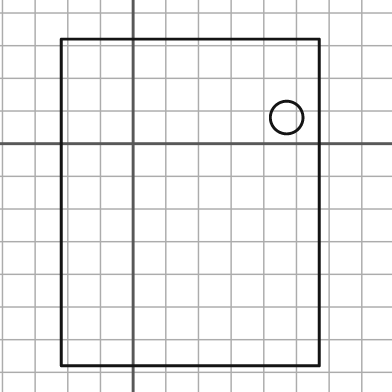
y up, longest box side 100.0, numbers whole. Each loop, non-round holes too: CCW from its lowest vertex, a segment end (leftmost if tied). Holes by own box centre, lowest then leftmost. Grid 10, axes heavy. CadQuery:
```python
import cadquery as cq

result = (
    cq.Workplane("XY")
    .moveTo(-22.0, -68.0)
    .lineTo(57.0, -68.0)
    .lineTo(57.0, 32.0)
    .lineTo(-22.0, 32.0)
    .close()
    .moveTo(47.0, 8.0)
    .circle(5.0)
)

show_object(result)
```